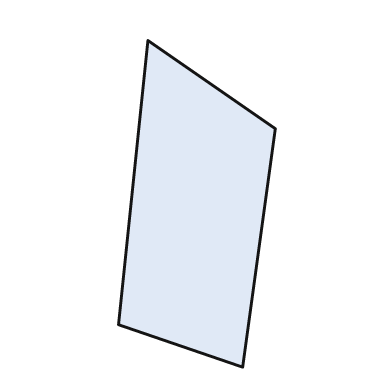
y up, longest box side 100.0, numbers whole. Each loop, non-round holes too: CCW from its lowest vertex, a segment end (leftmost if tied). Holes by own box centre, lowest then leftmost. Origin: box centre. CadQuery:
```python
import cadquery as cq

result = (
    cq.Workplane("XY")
    .moveTo(14.0, -50.0)
    .lineTo(24.0, 23.0)
    .lineTo(-15.0, 50.0)
    .lineTo(-24.0, -37.0)
    .close()
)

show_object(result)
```